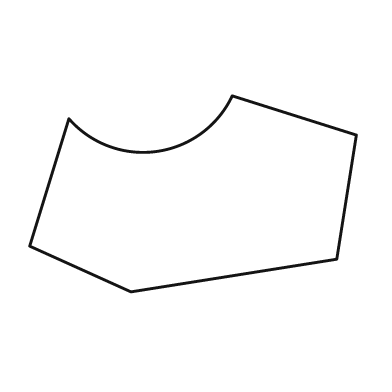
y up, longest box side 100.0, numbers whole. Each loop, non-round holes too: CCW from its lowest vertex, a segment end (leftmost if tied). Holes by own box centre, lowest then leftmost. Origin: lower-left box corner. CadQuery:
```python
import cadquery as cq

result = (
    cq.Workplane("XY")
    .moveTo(31.0, 0.0)
    .lineTo(94.0, 10.0)
    .lineTo(100.0, 48.0)
    .lineTo(62.0, 60.0)
    .threePointArc((39.0, 43.0), (12.0, 53.0))
    .lineTo(0.0, 14.0)
    .close()
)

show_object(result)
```